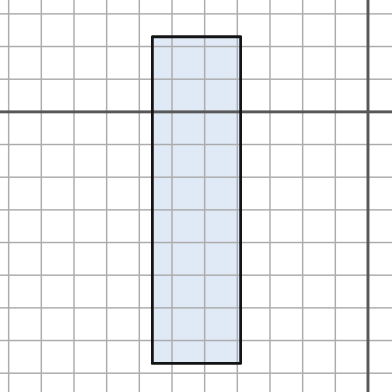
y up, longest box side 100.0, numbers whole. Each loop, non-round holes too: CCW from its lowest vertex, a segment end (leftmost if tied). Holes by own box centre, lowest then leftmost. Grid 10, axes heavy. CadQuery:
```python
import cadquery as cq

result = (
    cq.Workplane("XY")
    .moveTo(-66.0, -77.0)
    .lineTo(-39.0, -77.0)
    .lineTo(-39.0, 23.0)
    .lineTo(-66.0, 23.0)
    .close()
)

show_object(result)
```